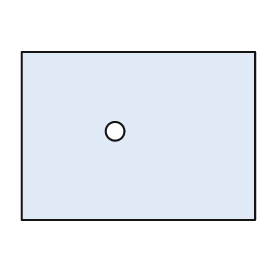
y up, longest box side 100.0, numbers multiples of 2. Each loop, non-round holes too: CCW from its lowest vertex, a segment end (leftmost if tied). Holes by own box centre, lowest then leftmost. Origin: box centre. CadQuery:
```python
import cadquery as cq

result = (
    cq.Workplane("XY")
    .moveTo(-50.0, -36.0)
    .lineTo(50.0, -36.0)
    .lineTo(50.0, 36.0)
    .lineTo(-50.0, 36.0)
    .close()
    .moveTo(-10.0, 2.0)
    .circle(4.0)
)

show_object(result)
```